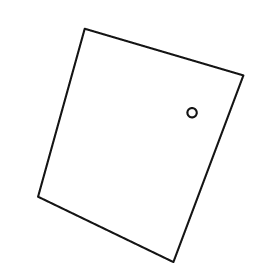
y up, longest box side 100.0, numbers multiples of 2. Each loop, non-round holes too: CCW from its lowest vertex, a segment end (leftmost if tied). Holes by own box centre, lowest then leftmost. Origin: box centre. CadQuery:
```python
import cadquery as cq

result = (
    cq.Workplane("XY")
    .moveTo(14.0, -50.0)
    .lineTo(44.0, 30.0)
    .lineTo(-24.0, 50.0)
    .lineTo(-44.0, -22.0)
    .close()
    .moveTo(22.0, 14.0)
    .circle(2.0)
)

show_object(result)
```